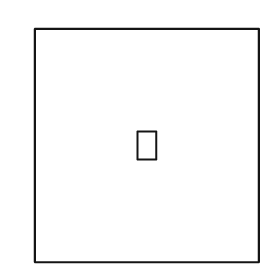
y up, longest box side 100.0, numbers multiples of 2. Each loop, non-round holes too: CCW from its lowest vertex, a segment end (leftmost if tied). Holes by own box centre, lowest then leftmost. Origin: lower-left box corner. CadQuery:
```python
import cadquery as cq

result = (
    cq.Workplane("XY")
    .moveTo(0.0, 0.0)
    .lineTo(96.0, 0.0)
    .lineTo(96.0, 100.0)
    .lineTo(0.0, 100.0)
    .close()
    .moveTo(44.0, 44.0)
    .lineTo(52.0, 44.0)
    .lineTo(52.0, 56.0)
    .lineTo(44.0, 56.0)
    .close()
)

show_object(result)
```